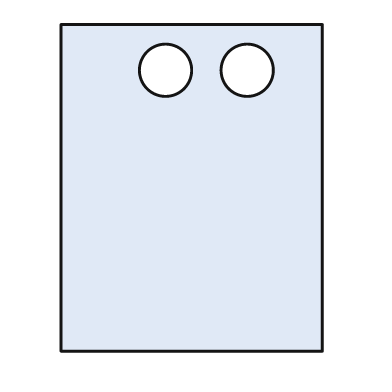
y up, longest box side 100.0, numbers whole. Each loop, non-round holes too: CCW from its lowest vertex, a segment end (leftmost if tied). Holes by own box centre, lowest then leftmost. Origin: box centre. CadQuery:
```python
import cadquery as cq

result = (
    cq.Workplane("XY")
    .moveTo(-40.0, -50.0)
    .lineTo(40.0, -50.0)
    .lineTo(40.0, 50.0)
    .lineTo(-40.0, 50.0)
    .close()
    .moveTo(-8.0, 36.0)
    .circle(8.0)
    .moveTo(17.0, 36.0)
    .circle(8.0)
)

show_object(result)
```